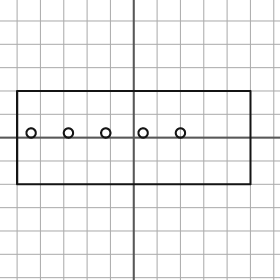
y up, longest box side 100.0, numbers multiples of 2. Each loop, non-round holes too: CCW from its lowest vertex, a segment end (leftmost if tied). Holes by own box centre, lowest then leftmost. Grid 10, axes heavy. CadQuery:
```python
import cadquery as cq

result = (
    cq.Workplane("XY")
    .moveTo(-50.0, -20.0)
    .lineTo(50.0, -20.0)
    .lineTo(50.0, 20.0)
    .lineTo(-50.0, 20.0)
    .close()
    .moveTo(-44.0, 2.0)
    .circle(2.0)
    .moveTo(-28.0, 2.0)
    .circle(2.0)
    .moveTo(-12.0, 2.0)
    .circle(2.0)
    .moveTo(4.0, 2.0)
    .circle(2.0)
    .moveTo(20.0, 2.0)
    .circle(2.0)
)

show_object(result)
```